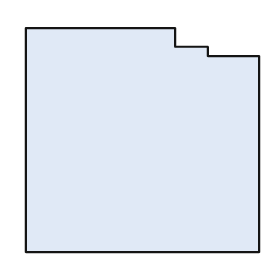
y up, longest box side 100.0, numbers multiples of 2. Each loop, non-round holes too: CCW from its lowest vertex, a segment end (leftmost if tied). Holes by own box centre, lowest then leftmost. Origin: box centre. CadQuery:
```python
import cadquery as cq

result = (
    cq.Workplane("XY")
    .moveTo(-50.0, -48.0)
    .lineTo(50.0, -48.0)
    .lineTo(50.0, 36.0)
    .lineTo(28.0, 36.0)
    .lineTo(28.0, 40.0)
    .lineTo(14.0, 40.0)
    .lineTo(14.0, 48.0)
    .lineTo(-50.0, 48.0)
    .close()
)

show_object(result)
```